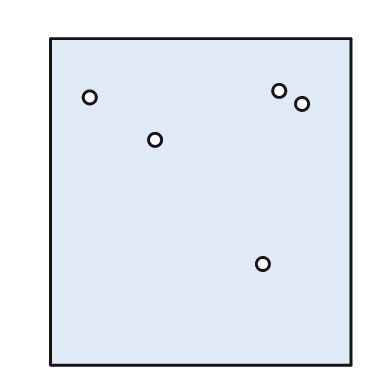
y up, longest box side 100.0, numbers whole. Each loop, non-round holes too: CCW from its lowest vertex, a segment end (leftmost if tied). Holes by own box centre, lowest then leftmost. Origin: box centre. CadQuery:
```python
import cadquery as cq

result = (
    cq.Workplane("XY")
    .moveTo(-46.0, -50.0)
    .lineTo(46.0, -50.0)
    .lineTo(46.0, 50.0)
    .lineTo(-46.0, 50.0)
    .close()
    .moveTo(19.0, -19.0)
    .circle(2.0)
    .moveTo(-14.0, 19.0)
    .circle(2.0)
    .moveTo(31.0, 30.0)
    .circle(2.0)
    .moveTo(-34.0, 32.0)
    .circle(2.0)
    .moveTo(24.0, 34.0)
    .circle(2.0)
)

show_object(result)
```